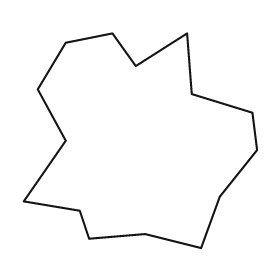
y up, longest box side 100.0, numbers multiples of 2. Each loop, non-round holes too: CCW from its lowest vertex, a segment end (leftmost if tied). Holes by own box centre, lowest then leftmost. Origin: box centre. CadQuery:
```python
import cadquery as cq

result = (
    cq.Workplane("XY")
    .moveTo(26.0, -46.0)
    .lineTo(34.0, -24.0)
    .lineTo(50.0, -4.0)
    .lineTo(48.0, 12.0)
    .lineTo(22.0, 20.0)
    .lineTo(20.0, 46.0)
    .lineTo(-2.0, 32.0)
    .lineTo(-12.0, 46.0)
    .lineTo(-32.0, 42.0)
    .lineTo(-44.0, 22.0)
    .lineTo(-32.0, 0.0)
    .lineTo(-50.0, -26.0)
    .lineTo(-26.0, -30.0)
    .lineTo(-22.0, -42.0)
    .lineTo(2.0, -40.0)
    .close()
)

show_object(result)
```